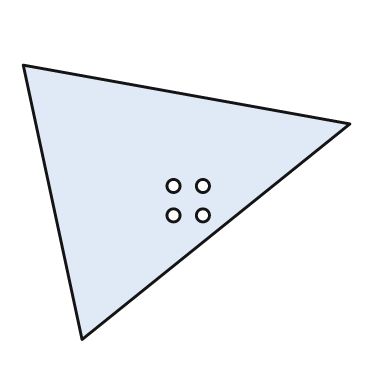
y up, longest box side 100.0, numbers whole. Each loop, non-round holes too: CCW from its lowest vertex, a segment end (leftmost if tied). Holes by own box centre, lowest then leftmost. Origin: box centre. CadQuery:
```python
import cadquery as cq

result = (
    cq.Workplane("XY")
    .moveTo(-32.0, -42.0)
    .lineTo(50.0, 24.0)
    .lineTo(-50.0, 42.0)
    .close()
    .moveTo(-4.0, -4.0)
    .circle(2.0)
    .moveTo(5.0, -4.0)
    .circle(2.0)
    .moveTo(-4.0, 5.0)
    .circle(2.0)
    .moveTo(5.0, 5.0)
    .circle(2.0)
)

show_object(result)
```